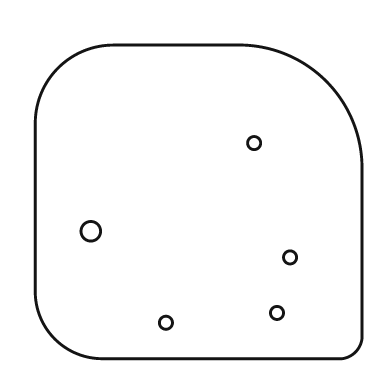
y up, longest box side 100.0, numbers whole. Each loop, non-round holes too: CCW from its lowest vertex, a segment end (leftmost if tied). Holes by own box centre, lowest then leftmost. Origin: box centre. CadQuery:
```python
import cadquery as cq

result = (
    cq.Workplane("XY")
    .moveTo(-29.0, -48.0)
    .lineTo(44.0, -48.0)
    .threePointArc((48.0, -46.0), (50.0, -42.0))
    .lineTo(50.0, 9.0)
    .threePointArc((39.0, 37.0), (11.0, 48.0))
    .lineTo(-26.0, 48.0)
    .threePointArc((-43.0, 41.0), (-50.0, 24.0))
    .lineTo(-50.0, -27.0)
    .threePointArc((-44.0, -42.0), (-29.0, -48.0))
    .close()
    .moveTo(-10.0, -37.0)
    .circle(2.0)
    .moveTo(24.0, -34.0)
    .circle(2.0)
    .moveTo(28.0, -17.0)
    .circle(2.0)
    .moveTo(-33.0, -9.0)
    .circle(3.0)
    .moveTo(17.0, 18.0)
    .circle(2.0)
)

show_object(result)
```